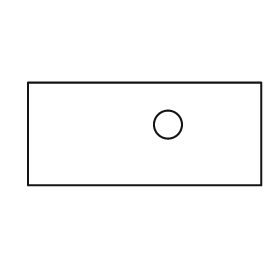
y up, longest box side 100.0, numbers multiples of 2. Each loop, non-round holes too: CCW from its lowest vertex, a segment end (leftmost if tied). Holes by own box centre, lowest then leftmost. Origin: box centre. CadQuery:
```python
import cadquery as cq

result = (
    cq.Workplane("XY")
    .moveTo(-50.0, -22.0)
    .lineTo(50.0, -22.0)
    .lineTo(50.0, 22.0)
    .lineTo(-50.0, 22.0)
    .close()
    .moveTo(10.0, 4.0)
    .circle(6.0)
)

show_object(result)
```